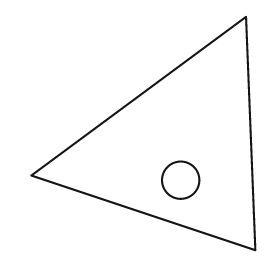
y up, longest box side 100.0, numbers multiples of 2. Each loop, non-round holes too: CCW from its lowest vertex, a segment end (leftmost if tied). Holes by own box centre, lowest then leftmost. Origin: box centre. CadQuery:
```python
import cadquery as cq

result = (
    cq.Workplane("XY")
    .moveTo(48.0, -50.0)
    .lineTo(44.0, 50.0)
    .lineTo(-48.0, -18.0)
    .close()
    .moveTo(16.0, -20.0)
    .circle(8.0)
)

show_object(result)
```